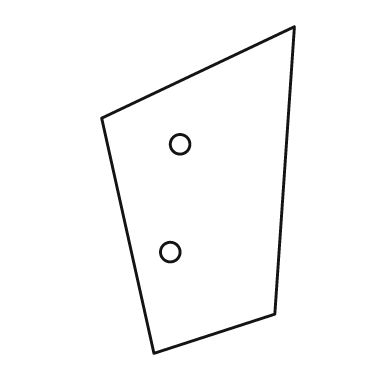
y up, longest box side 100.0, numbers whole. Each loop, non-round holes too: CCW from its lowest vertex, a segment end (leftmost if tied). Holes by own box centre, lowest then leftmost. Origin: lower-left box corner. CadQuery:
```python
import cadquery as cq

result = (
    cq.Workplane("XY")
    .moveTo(16.0, 0.0)
    .lineTo(53.0, 12.0)
    .lineTo(59.0, 100.0)
    .lineTo(0.0, 72.0)
    .close()
    .moveTo(21.0, 31.0)
    .circle(3.0)
    .moveTo(24.0, 64.0)
    .circle(3.0)
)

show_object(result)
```